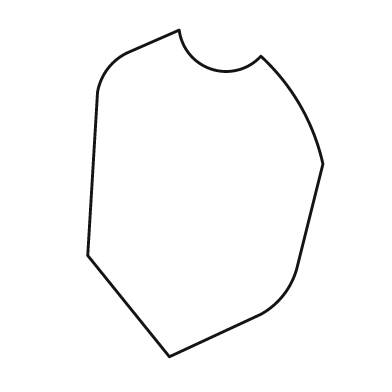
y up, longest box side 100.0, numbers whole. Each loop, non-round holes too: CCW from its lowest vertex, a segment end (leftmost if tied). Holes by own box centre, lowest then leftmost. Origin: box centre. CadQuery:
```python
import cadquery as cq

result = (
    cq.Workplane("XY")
    .moveTo(-11.0, -50.0)
    .lineTo(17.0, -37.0)
    .threePointArc((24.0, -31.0), (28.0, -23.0))
    .lineTo(36.0, 9.0)
    .threePointArc((29.0, 27.0), (17.0, 42.0))
    .threePointArc((2.0, 38.0), (-8.0, 50.0))
    .lineTo(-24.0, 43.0)
    .threePointArc((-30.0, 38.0), (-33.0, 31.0))
    .lineTo(-36.0, -19.0)
    .close()
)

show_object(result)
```